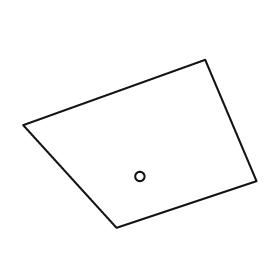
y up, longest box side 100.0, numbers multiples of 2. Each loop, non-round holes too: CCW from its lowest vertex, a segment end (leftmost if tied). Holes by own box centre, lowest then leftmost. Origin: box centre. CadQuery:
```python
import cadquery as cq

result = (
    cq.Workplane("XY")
    .moveTo(-10.0, -36.0)
    .lineTo(50.0, -16.0)
    .lineTo(28.0, 36.0)
    .lineTo(-50.0, 8.0)
    .close()
    .moveTo(0.0, -14.0)
    .circle(2.0)
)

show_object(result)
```